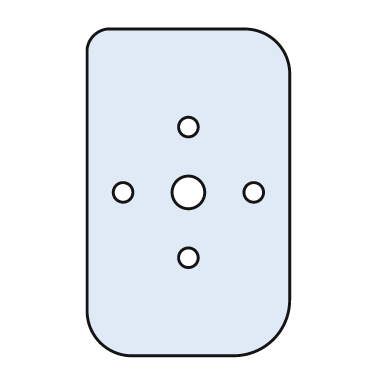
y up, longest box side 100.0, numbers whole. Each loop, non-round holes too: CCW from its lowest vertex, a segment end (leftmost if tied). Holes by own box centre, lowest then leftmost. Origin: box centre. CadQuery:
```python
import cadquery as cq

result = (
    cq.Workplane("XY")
    .moveTo(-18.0, -50.0)
    .lineTo(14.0, -50.0)
    .threePointArc((26.0, -45.0), (31.0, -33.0))
    .lineTo(31.0, 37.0)
    .threePointArc((27.0, 46.0), (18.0, 50.0))
    .lineTo(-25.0, 50.0)
    .threePointArc((-29.0, 48.0), (-31.0, 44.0))
    .lineTo(-31.0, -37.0)
    .threePointArc((-27.0, -46.0), (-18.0, -50.0))
    .close()
    .moveTo(0.0, -20.0)
    .circle(3.0)
    .moveTo(-20.0, 0.0)
    .circle(3.0)
    .moveTo(0.0, 0.0)
    .circle(5.0)
    .moveTo(20.0, 0.0)
    .circle(3.0)
    .moveTo(0.0, 20.0)
    .circle(3.0)
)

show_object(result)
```